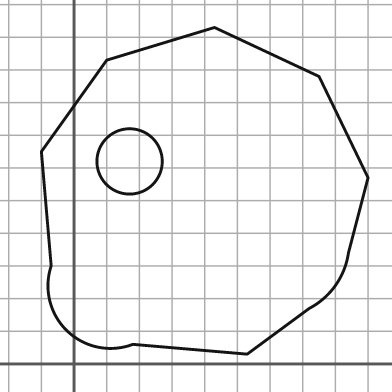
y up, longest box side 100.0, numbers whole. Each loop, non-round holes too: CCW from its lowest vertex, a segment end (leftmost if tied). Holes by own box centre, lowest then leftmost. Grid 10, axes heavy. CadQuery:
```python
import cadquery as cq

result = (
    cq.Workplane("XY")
    .moveTo(53.0, 3.0)
    .lineTo(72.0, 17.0)
    .threePointArc((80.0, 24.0), (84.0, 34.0))
    .lineTo(90.0, 57.0)
    .lineTo(75.0, 88.0)
    .lineTo(43.0, 103.0)
    .lineTo(10.0, 93.0)
    .lineTo(-10.0, 65.0)
    .lineTo(-7.0, 30.0)
    .threePointArc((-2.0, 10.0), (18.0, 6.0))
    .close()
    .moveTo(17.0, 62.0)
    .circle(10.0)
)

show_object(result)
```